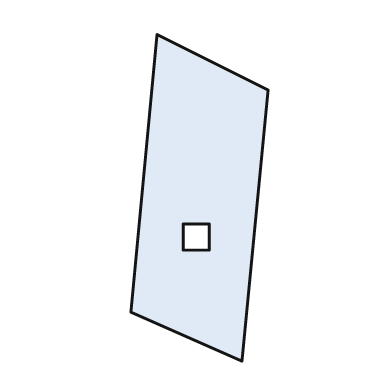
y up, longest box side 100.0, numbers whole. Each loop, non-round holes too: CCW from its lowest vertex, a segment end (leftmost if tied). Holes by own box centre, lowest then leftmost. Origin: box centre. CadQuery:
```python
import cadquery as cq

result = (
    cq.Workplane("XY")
    .moveTo(13.0, -50.0)
    .lineTo(21.0, 33.0)
    .lineTo(-13.0, 50.0)
    .lineTo(-21.0, -35.0)
    .close()
    .moveTo(-5.0, -16.0)
    .lineTo(3.0, -16.0)
    .lineTo(3.0, -8.0)
    .lineTo(-5.0, -8.0)
    .close()
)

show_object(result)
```